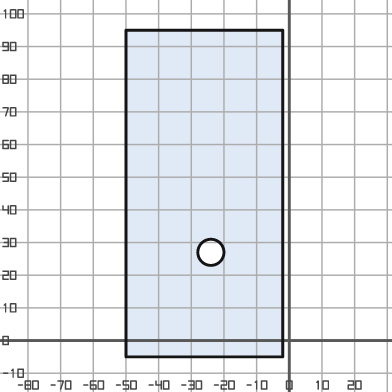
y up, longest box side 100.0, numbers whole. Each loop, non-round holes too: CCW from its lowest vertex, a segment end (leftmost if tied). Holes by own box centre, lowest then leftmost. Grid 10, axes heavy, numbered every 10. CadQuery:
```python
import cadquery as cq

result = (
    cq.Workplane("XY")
    .moveTo(-50.0, -5.0)
    .lineTo(-2.0, -5.0)
    .lineTo(-2.0, 95.0)
    .lineTo(-50.0, 95.0)
    .close()
    .moveTo(-24.0, 27.0)
    .circle(4.0)
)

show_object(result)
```